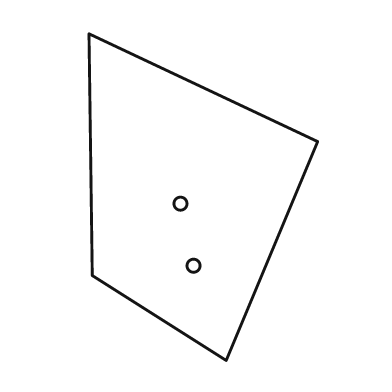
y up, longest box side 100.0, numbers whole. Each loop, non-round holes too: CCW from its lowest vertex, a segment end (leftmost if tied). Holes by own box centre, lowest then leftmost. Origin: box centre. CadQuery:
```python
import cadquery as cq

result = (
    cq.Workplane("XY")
    .moveTo(7.0, -50.0)
    .lineTo(35.0, 17.0)
    .lineTo(-35.0, 50.0)
    .lineTo(-34.0, -24.0)
    .close()
    .moveTo(-3.0, -21.0)
    .circle(2.0)
    .moveTo(-7.0, -2.0)
    .circle(2.0)
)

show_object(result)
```